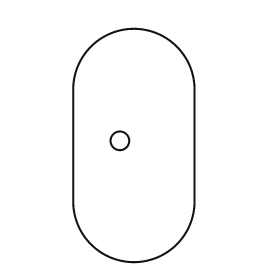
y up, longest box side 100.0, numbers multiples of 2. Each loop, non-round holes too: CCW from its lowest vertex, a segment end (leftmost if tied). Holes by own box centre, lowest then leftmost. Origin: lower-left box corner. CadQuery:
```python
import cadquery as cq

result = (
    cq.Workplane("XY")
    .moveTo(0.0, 26.0)
    .threePointArc((26.0, 0.0), (52.0, 26.0))
    .lineTo(52.0, 74.0)
    .threePointArc((26.0, 100.0), (0.0, 74.0))
    .close()
    .moveTo(20.0, 52.0)
    .circle(4.0)
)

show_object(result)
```